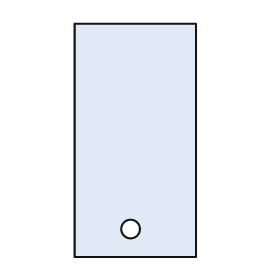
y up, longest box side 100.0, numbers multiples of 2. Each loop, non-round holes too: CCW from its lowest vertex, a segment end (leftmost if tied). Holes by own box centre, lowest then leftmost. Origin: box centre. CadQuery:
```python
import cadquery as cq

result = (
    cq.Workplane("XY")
    .moveTo(-26.0, -50.0)
    .lineTo(26.0, -50.0)
    .lineTo(26.0, 50.0)
    .lineTo(-26.0, 50.0)
    .close()
    .moveTo(-2.0, -38.0)
    .circle(4.0)
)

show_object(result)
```